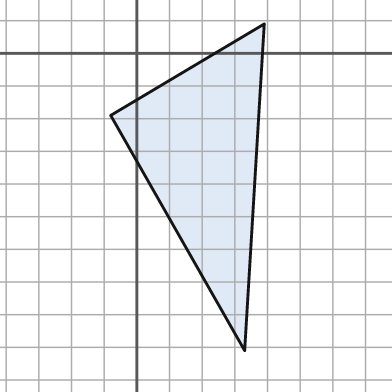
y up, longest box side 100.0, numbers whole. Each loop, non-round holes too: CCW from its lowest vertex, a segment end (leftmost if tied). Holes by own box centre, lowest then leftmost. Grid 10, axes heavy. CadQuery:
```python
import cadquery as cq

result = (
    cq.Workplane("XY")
    .moveTo(33.0, -91.0)
    .lineTo(39.0, 9.0)
    .lineTo(-8.0, -19.0)
    .close()
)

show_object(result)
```